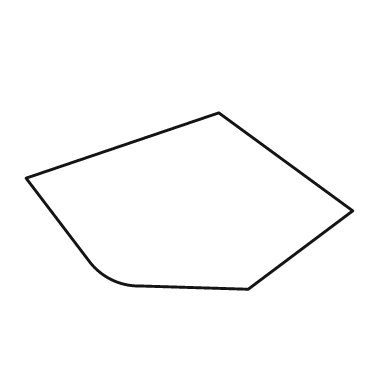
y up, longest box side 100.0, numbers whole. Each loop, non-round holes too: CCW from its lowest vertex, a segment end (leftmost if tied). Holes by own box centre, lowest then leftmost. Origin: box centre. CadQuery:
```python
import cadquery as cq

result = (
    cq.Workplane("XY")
    .moveTo(18.0, -27.0)
    .lineTo(50.0, -3.0)
    .lineTo(9.0, 27.0)
    .lineTo(-50.0, 7.0)
    .lineTo(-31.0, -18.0)
    .threePointArc((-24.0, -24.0), (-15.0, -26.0))
    .close()
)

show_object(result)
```